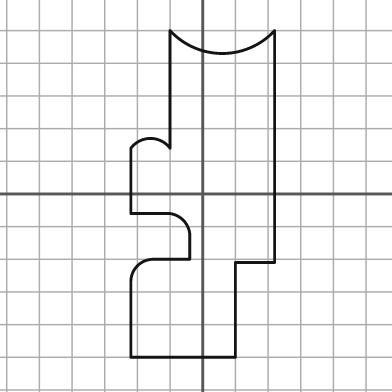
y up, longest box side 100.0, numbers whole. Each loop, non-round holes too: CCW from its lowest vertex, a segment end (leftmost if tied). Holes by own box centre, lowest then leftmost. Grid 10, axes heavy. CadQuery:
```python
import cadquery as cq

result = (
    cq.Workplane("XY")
    .moveTo(-22.0, -50.0)
    .lineTo(10.0, -50.0)
    .lineTo(10.0, -21.0)
    .lineTo(22.0, -21.0)
    .lineTo(22.0, 50.0)
    .threePointArc((6.0, 43.0), (-10.0, 50.0))
    .lineTo(-10.0, 14.0)
    .threePointArc((-16.0, 17.0), (-22.0, 14.0))
    .lineTo(-22.0, -6.0)
    .lineTo(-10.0, -6.0)
    .threePointArc((-6.0, -8.0), (-4.0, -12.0))
    .lineTo(-4.0, -20.0)
    .lineTo(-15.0, -20.0)
    .threePointArc((-20.0, -22.0), (-22.0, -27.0))
    .close()
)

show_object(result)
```